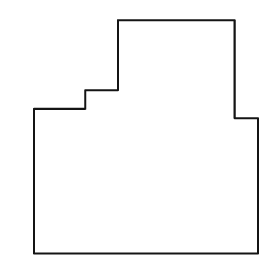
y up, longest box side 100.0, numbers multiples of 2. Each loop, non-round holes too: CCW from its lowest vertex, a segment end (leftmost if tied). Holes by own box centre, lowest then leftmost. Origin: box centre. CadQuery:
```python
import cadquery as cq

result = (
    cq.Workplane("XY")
    .moveTo(-48.0, -50.0)
    .lineTo(48.0, -50.0)
    .lineTo(48.0, 8.0)
    .lineTo(38.0, 8.0)
    .lineTo(38.0, 50.0)
    .lineTo(-12.0, 50.0)
    .lineTo(-12.0, 20.0)
    .lineTo(-26.0, 20.0)
    .lineTo(-26.0, 12.0)
    .lineTo(-48.0, 12.0)
    .close()
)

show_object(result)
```